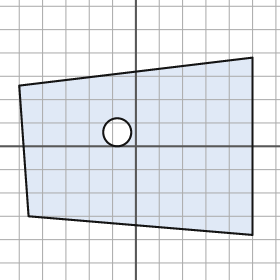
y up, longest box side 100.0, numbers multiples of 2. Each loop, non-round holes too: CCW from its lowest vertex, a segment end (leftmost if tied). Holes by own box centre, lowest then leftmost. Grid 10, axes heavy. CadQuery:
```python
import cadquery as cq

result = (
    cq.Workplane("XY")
    .moveTo(50.0, -38.0)
    .lineTo(50.0, 38.0)
    .lineTo(-50.0, 26.0)
    .lineTo(-46.0, -30.0)
    .close()
    .moveTo(-8.0, 6.0)
    .circle(6.0)
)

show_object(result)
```